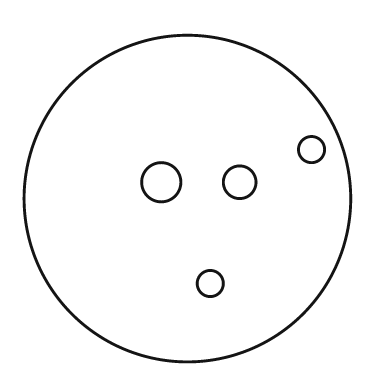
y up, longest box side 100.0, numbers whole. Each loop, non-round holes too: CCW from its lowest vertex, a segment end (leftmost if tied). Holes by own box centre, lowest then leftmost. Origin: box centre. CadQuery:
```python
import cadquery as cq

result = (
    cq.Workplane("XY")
    .moveTo(0.0, 0.0)
    .circle(50.0)
    .moveTo(7.0, -26.0)
    .circle(4.0)
    .moveTo(-8.0, 5.0)
    .circle(6.0)
    .moveTo(16.0, 5.0)
    .circle(5.0)
    .moveTo(38.0, 15.0)
    .circle(4.0)
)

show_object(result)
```